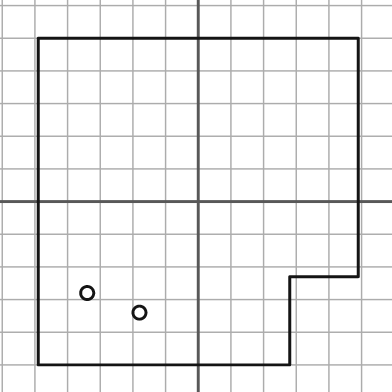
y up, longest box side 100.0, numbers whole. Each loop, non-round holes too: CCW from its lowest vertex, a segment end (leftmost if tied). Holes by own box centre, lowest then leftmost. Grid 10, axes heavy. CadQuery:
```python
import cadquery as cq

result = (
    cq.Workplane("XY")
    .moveTo(-49.0, -50.0)
    .lineTo(28.0, -50.0)
    .lineTo(28.0, -23.0)
    .lineTo(49.0, -23.0)
    .lineTo(49.0, 50.0)
    .lineTo(-49.0, 50.0)
    .close()
    .moveTo(-18.0, -34.0)
    .circle(2.0)
    .moveTo(-34.0, -28.0)
    .circle(2.0)
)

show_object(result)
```